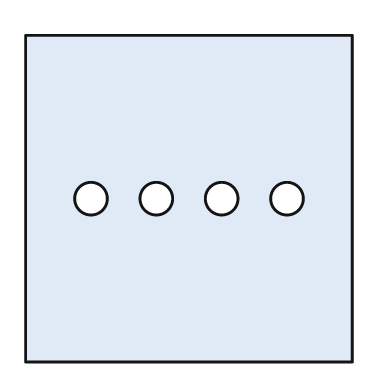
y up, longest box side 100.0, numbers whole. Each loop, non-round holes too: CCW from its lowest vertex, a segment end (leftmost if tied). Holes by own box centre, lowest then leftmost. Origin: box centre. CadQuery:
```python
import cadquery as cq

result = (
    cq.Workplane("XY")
    .moveTo(-50.0, -50.0)
    .lineTo(50.0, -50.0)
    .lineTo(50.0, 50.0)
    .lineTo(-50.0, 50.0)
    .close()
    .moveTo(-30.0, 0.0)
    .circle(5.0)
    .moveTo(-10.0, 0.0)
    .circle(5.0)
    .moveTo(10.0, 0.0)
    .circle(5.0)
    .moveTo(30.0, 0.0)
    .circle(5.0)
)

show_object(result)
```